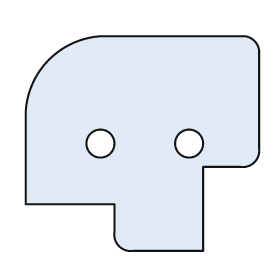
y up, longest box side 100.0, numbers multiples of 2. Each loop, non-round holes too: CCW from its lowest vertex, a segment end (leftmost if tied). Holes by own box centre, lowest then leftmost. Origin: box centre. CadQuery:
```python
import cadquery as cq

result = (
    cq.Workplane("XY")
    .moveTo(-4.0, -46.0)
    .lineTo(26.0, -46.0)
    .lineTo(26.0, -10.0)
    .lineTo(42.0, -10.0)
    .threePointArc((48.0, -8.0), (50.0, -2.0))
    .lineTo(50.0, 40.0)
    .threePointArc((48.0, 44.0), (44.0, 46.0))
    .lineTo(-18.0, 46.0)
    .threePointArc((-40.0, 36.0), (-50.0, 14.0))
    .lineTo(-50.0, -26.0)
    .lineTo(-12.0, -26.0)
    .lineTo(-12.0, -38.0)
    .threePointArc((-10.0, -44.0), (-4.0, -46.0))
    .close()
    .moveTo(-18.0, 0.0)
    .circle(6.0)
    .moveTo(20.0, 0.0)
    .circle(6.0)
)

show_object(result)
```